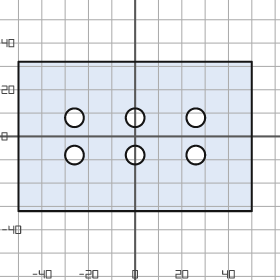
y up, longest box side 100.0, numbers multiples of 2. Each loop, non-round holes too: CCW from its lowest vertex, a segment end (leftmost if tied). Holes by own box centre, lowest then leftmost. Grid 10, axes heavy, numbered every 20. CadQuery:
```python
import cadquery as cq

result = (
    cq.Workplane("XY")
    .moveTo(-50.0, -32.0)
    .lineTo(50.0, -32.0)
    .lineTo(50.0, 32.0)
    .lineTo(-50.0, 32.0)
    .close()
    .moveTo(-26.0, -8.0)
    .circle(4.0)
    .moveTo(0.0, -8.0)
    .circle(4.0)
    .moveTo(26.0, -8.0)
    .circle(4.0)
    .moveTo(-26.0, 8.0)
    .circle(4.0)
    .moveTo(0.0, 8.0)
    .circle(4.0)
    .moveTo(26.0, 8.0)
    .circle(4.0)
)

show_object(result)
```